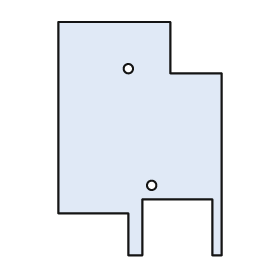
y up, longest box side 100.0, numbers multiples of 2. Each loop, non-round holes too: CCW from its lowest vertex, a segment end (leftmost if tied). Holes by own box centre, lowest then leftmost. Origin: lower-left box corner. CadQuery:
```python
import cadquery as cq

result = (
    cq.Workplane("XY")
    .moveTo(30.0, 0.0)
    .lineTo(36.0, 0.0)
    .lineTo(36.0, 24.0)
    .lineTo(66.0, 24.0)
    .lineTo(66.0, 0.0)
    .lineTo(70.0, 0.0)
    .lineTo(70.0, 78.0)
    .lineTo(48.0, 78.0)
    .lineTo(48.0, 100.0)
    .lineTo(0.0, 100.0)
    .lineTo(0.0, 18.0)
    .lineTo(30.0, 18.0)
    .close()
    .moveTo(40.0, 30.0)
    .circle(2.0)
    .moveTo(30.0, 80.0)
    .circle(2.0)
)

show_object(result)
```